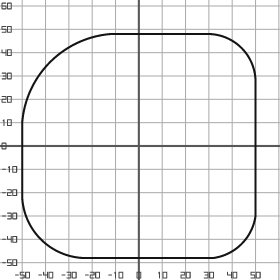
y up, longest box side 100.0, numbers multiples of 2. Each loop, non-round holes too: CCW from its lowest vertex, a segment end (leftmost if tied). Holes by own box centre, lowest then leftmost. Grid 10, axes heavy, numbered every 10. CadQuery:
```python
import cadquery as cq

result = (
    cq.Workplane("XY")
    .moveTo(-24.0, -48.0)
    .lineTo(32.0, -48.0)
    .threePointArc((44.0, -42.0), (50.0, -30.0))
    .lineTo(50.0, 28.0)
    .threePointArc((44.0, 42.0), (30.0, 48.0))
    .lineTo(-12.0, 48.0)
    .threePointArc((-38.0, 36.0), (-50.0, 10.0))
    .lineTo(-50.0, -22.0)
    .threePointArc((-42.0, -40.0), (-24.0, -48.0))
    .close()
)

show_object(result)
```